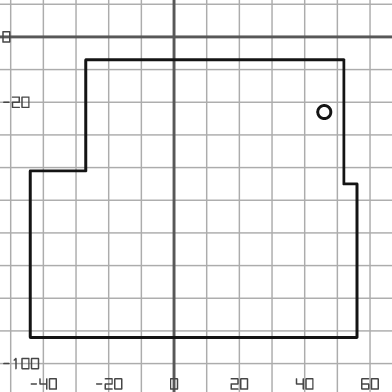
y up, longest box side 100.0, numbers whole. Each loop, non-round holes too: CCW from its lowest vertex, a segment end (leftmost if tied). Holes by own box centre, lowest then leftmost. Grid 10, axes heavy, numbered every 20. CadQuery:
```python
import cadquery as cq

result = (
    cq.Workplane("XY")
    .moveTo(-44.0, -92.0)
    .lineTo(56.0, -92.0)
    .lineTo(56.0, -45.0)
    .lineTo(52.0, -45.0)
    .lineTo(52.0, -7.0)
    .lineTo(-27.0, -7.0)
    .lineTo(-27.0, -41.0)
    .lineTo(-44.0, -41.0)
    .close()
    .moveTo(46.0, -23.0)
    .circle(2.0)
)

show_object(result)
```